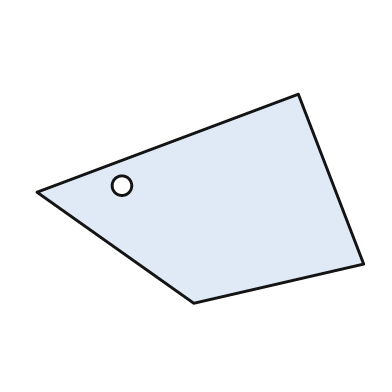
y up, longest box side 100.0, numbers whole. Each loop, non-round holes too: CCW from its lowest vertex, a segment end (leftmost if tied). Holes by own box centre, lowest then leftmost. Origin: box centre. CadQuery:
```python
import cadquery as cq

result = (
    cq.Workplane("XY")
    .moveTo(-2.0, -32.0)
    .lineTo(50.0, -20.0)
    .lineTo(30.0, 32.0)
    .lineTo(-50.0, 2.0)
    .close()
    .moveTo(-24.0, 4.0)
    .circle(3.0)
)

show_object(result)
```